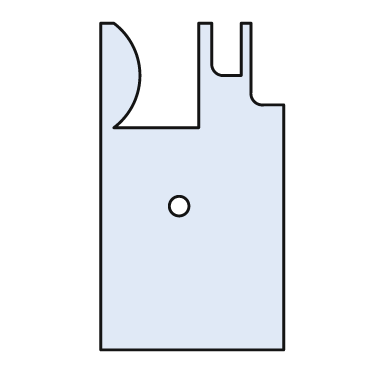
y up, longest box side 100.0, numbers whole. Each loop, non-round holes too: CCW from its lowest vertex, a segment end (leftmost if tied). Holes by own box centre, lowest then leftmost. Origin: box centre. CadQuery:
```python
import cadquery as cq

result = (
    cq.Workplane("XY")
    .moveTo(-28.0, -50.0)
    .lineTo(28.0, -50.0)
    .lineTo(28.0, 25.0)
    .lineTo(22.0, 25.0)
    .threePointArc((19.0, 26.0), (18.0, 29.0))
    .lineTo(18.0, 50.0)
    .lineTo(15.0, 50.0)
    .lineTo(15.0, 34.0)
    .lineTo(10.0, 34.0)
    .threePointArc((7.0, 35.0), (6.0, 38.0))
    .lineTo(6.0, 50.0)
    .lineTo(2.0, 50.0)
    .lineTo(2.0, 18.0)
    .lineTo(-24.0, 18.0)
    .threePointArc((-16.0, 34.0), (-24.0, 50.0))
    .lineTo(-28.0, 50.0)
    .close()
    .moveTo(-4.0, -6.0)
    .circle(3.0)
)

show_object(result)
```